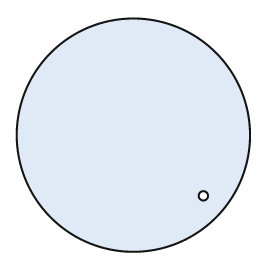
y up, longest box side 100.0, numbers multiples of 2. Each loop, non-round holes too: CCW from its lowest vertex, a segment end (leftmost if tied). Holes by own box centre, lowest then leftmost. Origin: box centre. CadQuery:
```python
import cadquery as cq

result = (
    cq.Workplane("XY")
    .moveTo(0.0, 0.0)
    .circle(50.0)
    .moveTo(30.0, -26.0)
    .circle(2.0)
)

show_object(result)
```